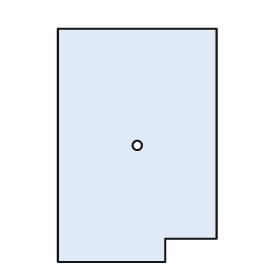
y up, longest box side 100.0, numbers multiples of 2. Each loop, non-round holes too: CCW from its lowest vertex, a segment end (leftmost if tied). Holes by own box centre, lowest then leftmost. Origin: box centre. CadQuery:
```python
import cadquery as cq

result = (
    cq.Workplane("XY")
    .moveTo(-34.0, -50.0)
    .lineTo(12.0, -50.0)
    .lineTo(12.0, -40.0)
    .lineTo(34.0, -40.0)
    .lineTo(34.0, 50.0)
    .lineTo(-34.0, 50.0)
    .close()
    .moveTo(0.0, 0.0)
    .circle(2.0)
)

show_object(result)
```